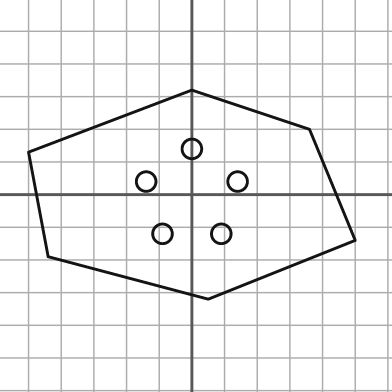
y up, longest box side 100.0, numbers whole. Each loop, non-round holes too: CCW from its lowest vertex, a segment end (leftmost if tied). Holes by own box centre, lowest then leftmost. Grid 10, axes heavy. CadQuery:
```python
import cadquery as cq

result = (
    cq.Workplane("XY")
    .moveTo(5.0, -32.0)
    .lineTo(50.0, -14.0)
    .lineTo(36.0, 20.0)
    .lineTo(0.0, 32.0)
    .lineTo(-50.0, 13.0)
    .lineTo(-44.0, -19.0)
    .close()
    .moveTo(-9.0, -12.0)
    .circle(3.0)
    .moveTo(9.0, -12.0)
    .circle(3.0)
    .moveTo(-14.0, 4.0)
    .circle(3.0)
    .moveTo(14.0, 4.0)
    .circle(3.0)
    .moveTo(0.0, 14.0)
    .circle(3.0)
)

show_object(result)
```